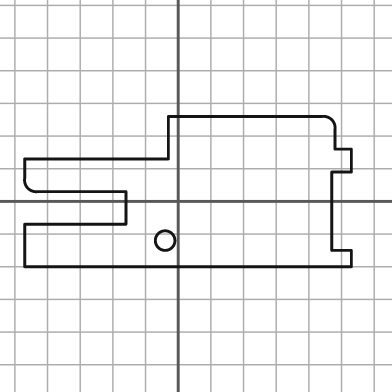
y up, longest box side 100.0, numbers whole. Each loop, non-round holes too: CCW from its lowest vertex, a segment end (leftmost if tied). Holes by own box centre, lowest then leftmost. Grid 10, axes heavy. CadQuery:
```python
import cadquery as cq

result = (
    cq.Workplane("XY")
    .moveTo(-47.0, -20.0)
    .lineTo(53.0, -20.0)
    .lineTo(53.0, -15.0)
    .lineTo(47.0, -15.0)
    .lineTo(47.0, 9.0)
    .lineTo(53.0, 9.0)
    .lineTo(53.0, 16.0)
    .lineTo(48.0, 16.0)
    .lineTo(48.0, 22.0)
    .threePointArc((47.0, 25.0), (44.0, 26.0))
    .lineTo(-3.0, 26.0)
    .lineTo(-3.0, 13.0)
    .lineTo(-47.0, 13.0)
    .lineTo(-47.0, 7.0)
    .threePointArc((-46.0, 4.0), (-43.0, 3.0))
    .lineTo(-16.0, 3.0)
    .lineTo(-16.0, -7.0)
    .lineTo(-47.0, -7.0)
    .close()
    .moveTo(-4.0, -12.0)
    .circle(3.0)
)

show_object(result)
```